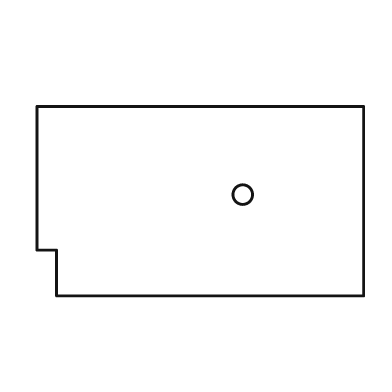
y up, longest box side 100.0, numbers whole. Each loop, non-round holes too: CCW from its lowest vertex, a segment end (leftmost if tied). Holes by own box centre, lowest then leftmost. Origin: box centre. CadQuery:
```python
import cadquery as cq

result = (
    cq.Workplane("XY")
    .moveTo(-44.0, -29.0)
    .lineTo(50.0, -29.0)
    .lineTo(50.0, 29.0)
    .lineTo(-50.0, 29.0)
    .lineTo(-50.0, -15.0)
    .lineTo(-44.0, -15.0)
    .close()
    .moveTo(13.0, 2.0)
    .circle(3.0)
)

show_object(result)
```